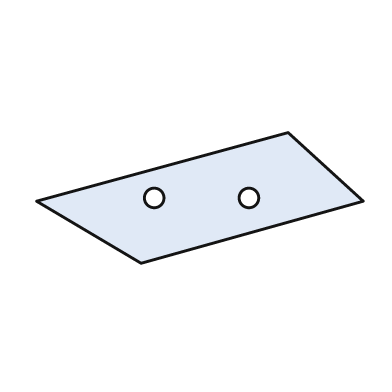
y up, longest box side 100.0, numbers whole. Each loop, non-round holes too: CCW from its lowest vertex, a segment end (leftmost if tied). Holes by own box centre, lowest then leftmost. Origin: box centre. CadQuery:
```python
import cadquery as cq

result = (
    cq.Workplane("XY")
    .moveTo(-18.0, -20.0)
    .lineTo(50.0, -1.0)
    .lineTo(27.0, 20.0)
    .lineTo(-50.0, -1.0)
    .close()
    .moveTo(-14.0, 0.0)
    .circle(3.0)
    .moveTo(15.0, 0.0)
    .circle(3.0)
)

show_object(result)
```